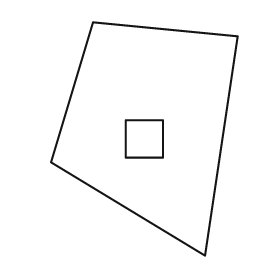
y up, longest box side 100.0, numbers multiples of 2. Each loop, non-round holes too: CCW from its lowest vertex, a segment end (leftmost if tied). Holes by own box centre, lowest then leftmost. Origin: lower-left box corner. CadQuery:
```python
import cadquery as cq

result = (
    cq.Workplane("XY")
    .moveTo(66.0, 0.0)
    .lineTo(80.0, 94.0)
    .lineTo(18.0, 100.0)
    .lineTo(0.0, 40.0)
    .close()
    .moveTo(32.0, 42.0)
    .lineTo(48.0, 42.0)
    .lineTo(48.0, 58.0)
    .lineTo(32.0, 58.0)
    .close()
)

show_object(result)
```